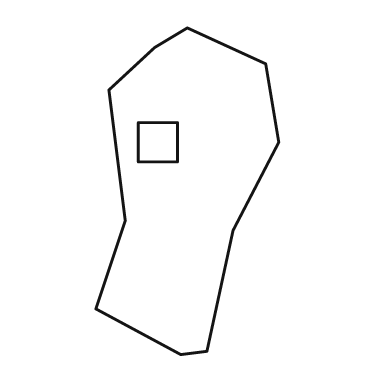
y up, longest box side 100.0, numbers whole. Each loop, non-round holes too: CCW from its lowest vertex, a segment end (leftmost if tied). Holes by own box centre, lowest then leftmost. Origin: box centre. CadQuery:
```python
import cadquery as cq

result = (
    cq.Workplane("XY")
    .moveTo(-2.0, -50.0)
    .lineTo(6.0, -49.0)
    .lineTo(14.0, -12.0)
    .lineTo(28.0, 15.0)
    .lineTo(24.0, 39.0)
    .lineTo(0.0, 50.0)
    .lineTo(-10.0, 44.0)
    .lineTo(-24.0, 31.0)
    .lineTo(-19.0, -9.0)
    .lineTo(-28.0, -36.0)
    .close()
    .moveTo(-15.0, 9.0)
    .lineTo(-3.0, 9.0)
    .lineTo(-3.0, 21.0)
    .lineTo(-15.0, 21.0)
    .close()
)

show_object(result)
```